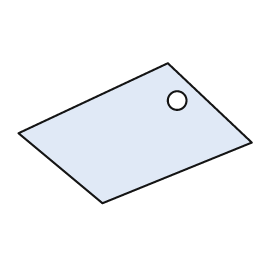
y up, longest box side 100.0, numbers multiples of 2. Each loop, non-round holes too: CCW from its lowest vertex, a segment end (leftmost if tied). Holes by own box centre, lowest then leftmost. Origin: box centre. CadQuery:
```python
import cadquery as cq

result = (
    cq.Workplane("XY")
    .moveTo(-14.0, -30.0)
    .lineTo(50.0, -4.0)
    .lineTo(14.0, 30.0)
    .lineTo(-50.0, 0.0)
    .close()
    .moveTo(18.0, 14.0)
    .circle(4.0)
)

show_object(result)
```